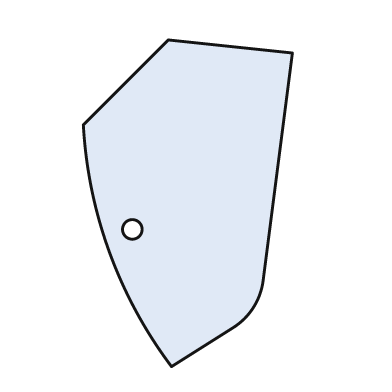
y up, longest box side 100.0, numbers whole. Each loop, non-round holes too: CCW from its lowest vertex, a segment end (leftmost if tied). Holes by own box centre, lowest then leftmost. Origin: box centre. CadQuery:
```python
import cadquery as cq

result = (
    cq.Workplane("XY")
    .moveTo(-5.0, -50.0)
    .lineTo(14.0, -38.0)
    .threePointArc((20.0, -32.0), (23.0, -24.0))
    .lineTo(32.0, 46.0)
    .lineTo(-6.0, 50.0)
    .lineTo(-32.0, 24.0)
    .threePointArc((-24.0, -15.0), (-5.0, -50.0))
    .close()
    .moveTo(-17.0, -8.0)
    .circle(3.0)
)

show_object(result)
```